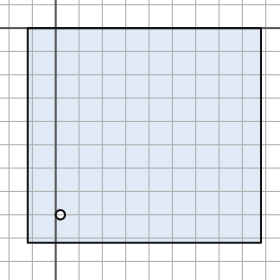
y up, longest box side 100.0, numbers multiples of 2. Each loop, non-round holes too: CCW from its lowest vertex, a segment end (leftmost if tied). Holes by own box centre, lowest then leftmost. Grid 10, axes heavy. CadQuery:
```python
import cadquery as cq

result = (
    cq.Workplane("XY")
    .moveTo(-12.0, -92.0)
    .lineTo(88.0, -92.0)
    .lineTo(88.0, 0.0)
    .lineTo(-12.0, 0.0)
    .close()
    .moveTo(2.0, -80.0)
    .circle(2.0)
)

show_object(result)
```